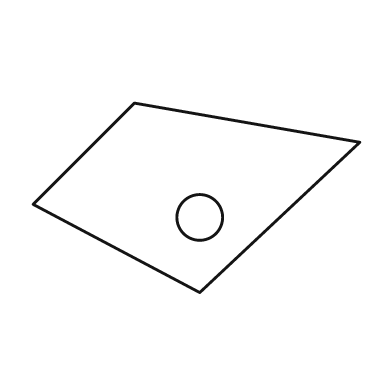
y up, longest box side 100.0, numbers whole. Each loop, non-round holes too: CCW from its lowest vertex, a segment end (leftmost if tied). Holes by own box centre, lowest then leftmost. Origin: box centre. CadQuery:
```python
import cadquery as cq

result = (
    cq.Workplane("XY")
    .moveTo(1.0, -29.0)
    .lineTo(50.0, 17.0)
    .lineTo(-19.0, 29.0)
    .lineTo(-50.0, -2.0)
    .close()
    .moveTo(1.0, -6.0)
    .circle(7.0)
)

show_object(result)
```